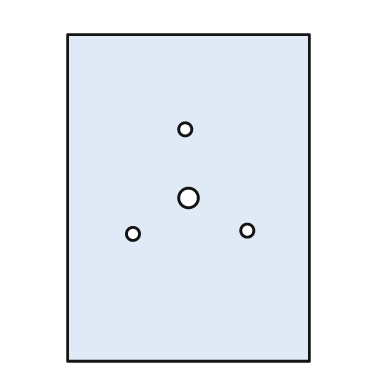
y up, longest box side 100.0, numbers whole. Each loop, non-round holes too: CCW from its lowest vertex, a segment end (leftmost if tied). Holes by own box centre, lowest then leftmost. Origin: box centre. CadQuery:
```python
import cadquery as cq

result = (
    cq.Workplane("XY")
    .moveTo(-37.0, -50.0)
    .lineTo(37.0, -50.0)
    .lineTo(37.0, 50.0)
    .lineTo(-37.0, 50.0)
    .close()
    .moveTo(-17.0, -11.0)
    .circle(2.0)
    .moveTo(18.0, -10.0)
    .circle(2.0)
    .moveTo(0.0, 0.0)
    .circle(3.0)
    .moveTo(-1.0, 21.0)
    .circle(2.0)
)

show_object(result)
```